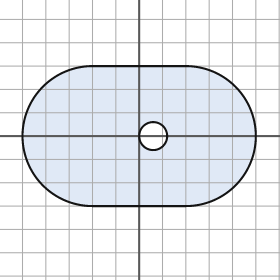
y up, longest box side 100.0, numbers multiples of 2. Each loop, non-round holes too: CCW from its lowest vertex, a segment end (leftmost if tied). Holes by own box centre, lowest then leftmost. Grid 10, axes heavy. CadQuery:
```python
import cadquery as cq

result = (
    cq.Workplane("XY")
    .moveTo(-20.0, -30.0)
    .lineTo(20.0, -30.0)
    .threePointArc((50.0, 0.0), (20.0, 30.0))
    .lineTo(-20.0, 30.0)
    .threePointArc((-50.0, 0.0), (-20.0, -30.0))
    .close()
    .moveTo(6.0, 0.0)
    .circle(6.0)
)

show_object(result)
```